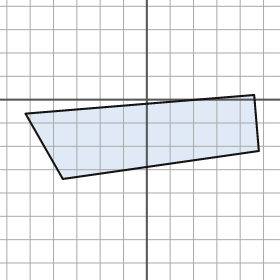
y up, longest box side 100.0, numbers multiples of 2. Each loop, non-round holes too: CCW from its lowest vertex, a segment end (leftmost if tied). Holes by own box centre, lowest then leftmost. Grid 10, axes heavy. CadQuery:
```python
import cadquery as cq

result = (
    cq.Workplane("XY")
    .moveTo(-36.0, -34.0)
    .lineTo(48.0, -22.0)
    .lineTo(46.0, 2.0)
    .lineTo(-52.0, -6.0)
    .close()
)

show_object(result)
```